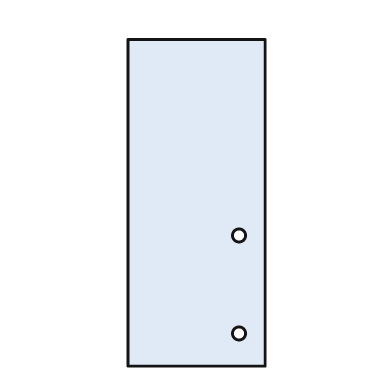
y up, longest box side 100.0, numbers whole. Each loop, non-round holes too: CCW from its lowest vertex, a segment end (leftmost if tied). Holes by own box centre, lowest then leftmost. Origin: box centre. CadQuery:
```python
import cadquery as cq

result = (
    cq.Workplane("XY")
    .moveTo(-21.0, -50.0)
    .lineTo(21.0, -50.0)
    .lineTo(21.0, 50.0)
    .lineTo(-21.0, 50.0)
    .close()
    .moveTo(13.0, -40.0)
    .circle(2.0)
    .moveTo(13.0, -10.0)
    .circle(2.0)
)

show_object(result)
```